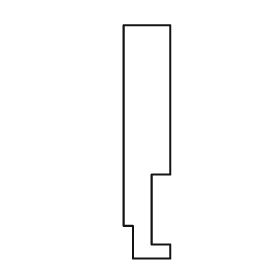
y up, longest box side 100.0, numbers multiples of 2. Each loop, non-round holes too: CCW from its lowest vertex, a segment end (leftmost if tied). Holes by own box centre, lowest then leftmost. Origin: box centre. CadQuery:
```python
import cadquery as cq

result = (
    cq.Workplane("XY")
    .moveTo(-6.0, -50.0)
    .lineTo(10.0, -50.0)
    .lineTo(10.0, -44.0)
    .lineTo(2.0, -44.0)
    .lineTo(2.0, -14.0)
    .lineTo(10.0, -14.0)
    .lineTo(10.0, 50.0)
    .lineTo(-10.0, 50.0)
    .lineTo(-10.0, -36.0)
    .lineTo(-6.0, -36.0)
    .close()
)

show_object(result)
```